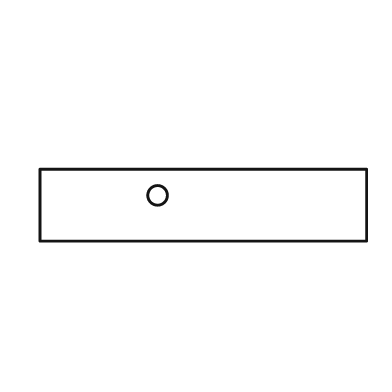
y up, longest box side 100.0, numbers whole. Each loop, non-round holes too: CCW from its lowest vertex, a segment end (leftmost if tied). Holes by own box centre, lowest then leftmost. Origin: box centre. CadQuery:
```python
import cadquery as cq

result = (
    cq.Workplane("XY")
    .moveTo(-50.0, -11.0)
    .lineTo(50.0, -11.0)
    .lineTo(50.0, 11.0)
    .lineTo(-50.0, 11.0)
    .close()
    .moveTo(-14.0, 3.0)
    .circle(3.0)
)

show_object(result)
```